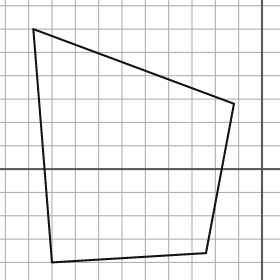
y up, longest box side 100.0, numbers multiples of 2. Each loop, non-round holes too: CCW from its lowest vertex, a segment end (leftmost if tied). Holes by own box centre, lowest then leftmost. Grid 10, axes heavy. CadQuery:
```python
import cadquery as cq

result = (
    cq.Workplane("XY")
    .moveTo(-90.0, -40.0)
    .lineTo(-24.0, -36.0)
    .lineTo(-12.0, 28.0)
    .lineTo(-98.0, 60.0)
    .close()
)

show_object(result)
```